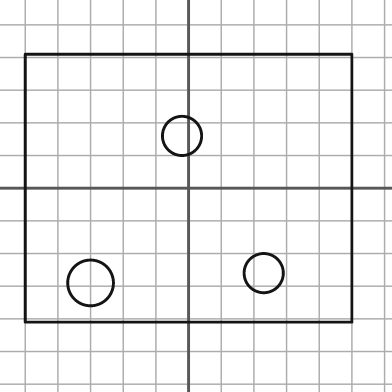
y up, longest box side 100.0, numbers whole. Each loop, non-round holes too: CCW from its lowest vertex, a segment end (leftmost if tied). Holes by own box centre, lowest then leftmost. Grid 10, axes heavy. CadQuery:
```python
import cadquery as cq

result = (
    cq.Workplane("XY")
    .moveTo(-50.0, -41.0)
    .lineTo(50.0, -41.0)
    .lineTo(50.0, 41.0)
    .lineTo(-50.0, 41.0)
    .close()
    .moveTo(-30.0, -29.0)
    .circle(7.0)
    .moveTo(23.0, -26.0)
    .circle(6.0)
    .moveTo(-2.0, 16.0)
    .circle(6.0)
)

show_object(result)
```